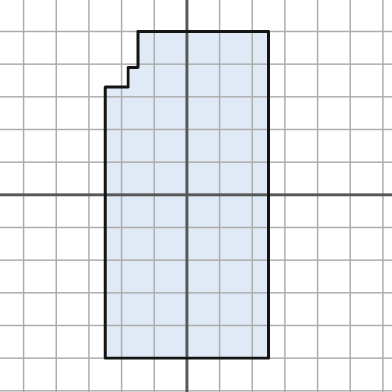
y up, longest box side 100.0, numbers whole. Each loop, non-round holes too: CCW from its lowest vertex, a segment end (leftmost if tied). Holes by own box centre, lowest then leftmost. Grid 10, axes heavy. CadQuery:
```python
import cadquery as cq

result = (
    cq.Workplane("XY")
    .moveTo(-25.0, -50.0)
    .lineTo(25.0, -50.0)
    .lineTo(25.0, 50.0)
    .lineTo(-15.0, 50.0)
    .lineTo(-15.0, 39.0)
    .lineTo(-18.0, 39.0)
    .lineTo(-18.0, 33.0)
    .lineTo(-25.0, 33.0)
    .close()
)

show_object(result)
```